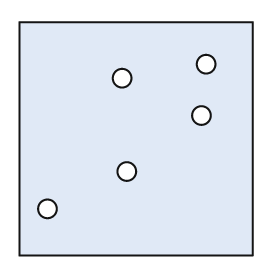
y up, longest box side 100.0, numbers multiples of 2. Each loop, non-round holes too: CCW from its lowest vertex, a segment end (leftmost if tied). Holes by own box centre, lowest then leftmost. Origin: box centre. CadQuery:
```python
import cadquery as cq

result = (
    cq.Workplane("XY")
    .moveTo(-50.0, -50.0)
    .lineTo(50.0, -50.0)
    .lineTo(50.0, 50.0)
    .lineTo(-50.0, 50.0)
    .close()
    .moveTo(-38.0, -30.0)
    .circle(4.0)
    .moveTo(-4.0, -14.0)
    .circle(4.0)
    .moveTo(28.0, 10.0)
    .circle(4.0)
    .moveTo(-6.0, 26.0)
    .circle(4.0)
    .moveTo(30.0, 32.0)
    .circle(4.0)
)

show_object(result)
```